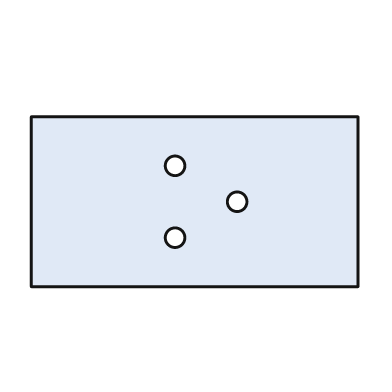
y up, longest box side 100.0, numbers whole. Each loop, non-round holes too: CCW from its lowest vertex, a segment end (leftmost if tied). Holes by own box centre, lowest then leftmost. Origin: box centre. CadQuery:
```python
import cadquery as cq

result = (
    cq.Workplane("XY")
    .moveTo(-50.0, -26.0)
    .lineTo(50.0, -26.0)
    .lineTo(50.0, 26.0)
    .lineTo(-50.0, 26.0)
    .close()
    .moveTo(-6.0, -11.0)
    .circle(3.0)
    .moveTo(13.0, 0.0)
    .circle(3.0)
    .moveTo(-6.0, 11.0)
    .circle(3.0)
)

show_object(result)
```